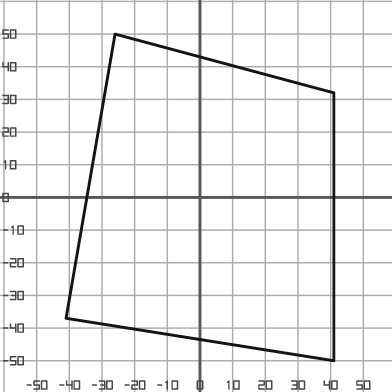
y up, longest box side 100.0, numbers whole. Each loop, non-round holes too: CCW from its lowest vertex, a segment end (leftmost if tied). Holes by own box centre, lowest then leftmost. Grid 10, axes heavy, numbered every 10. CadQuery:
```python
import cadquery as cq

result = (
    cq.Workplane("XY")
    .moveTo(41.0, -50.0)
    .lineTo(41.0, 32.0)
    .lineTo(-26.0, 50.0)
    .lineTo(-41.0, -37.0)
    .close()
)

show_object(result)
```